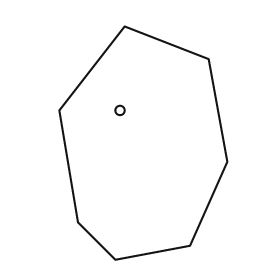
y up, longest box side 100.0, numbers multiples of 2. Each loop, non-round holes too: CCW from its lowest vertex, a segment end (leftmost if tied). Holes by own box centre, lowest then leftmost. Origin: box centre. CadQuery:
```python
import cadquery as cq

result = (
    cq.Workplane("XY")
    .moveTo(-12.0, -50.0)
    .lineTo(20.0, -44.0)
    .lineTo(36.0, -8.0)
    .lineTo(28.0, 36.0)
    .lineTo(-8.0, 50.0)
    .lineTo(-36.0, 14.0)
    .lineTo(-28.0, -34.0)
    .close()
    .moveTo(-10.0, 14.0)
    .circle(2.0)
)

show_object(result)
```